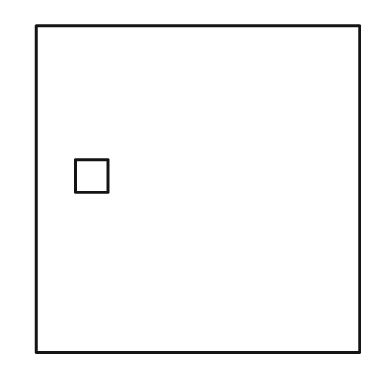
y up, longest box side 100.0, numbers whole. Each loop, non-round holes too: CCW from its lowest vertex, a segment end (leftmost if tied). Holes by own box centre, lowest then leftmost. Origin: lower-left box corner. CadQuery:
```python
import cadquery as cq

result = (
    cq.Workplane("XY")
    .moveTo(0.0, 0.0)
    .lineTo(99.0, 0.0)
    .lineTo(99.0, 100.0)
    .lineTo(0.0, 100.0)
    .close()
    .moveTo(12.0, 49.0)
    .lineTo(22.0, 49.0)
    .lineTo(22.0, 59.0)
    .lineTo(12.0, 59.0)
    .close()
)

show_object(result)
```